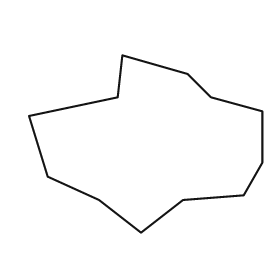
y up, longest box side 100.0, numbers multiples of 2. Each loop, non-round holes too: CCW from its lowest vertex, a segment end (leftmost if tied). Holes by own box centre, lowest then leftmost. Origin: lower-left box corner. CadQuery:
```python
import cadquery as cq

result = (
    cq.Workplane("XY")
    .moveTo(48.0, 0.0)
    .lineTo(66.0, 14.0)
    .lineTo(92.0, 16.0)
    .lineTo(100.0, 30.0)
    .lineTo(100.0, 52.0)
    .lineTo(78.0, 58.0)
    .lineTo(68.0, 68.0)
    .lineTo(40.0, 76.0)
    .lineTo(38.0, 58.0)
    .lineTo(0.0, 50.0)
    .lineTo(8.0, 24.0)
    .lineTo(30.0, 14.0)
    .close()
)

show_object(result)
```